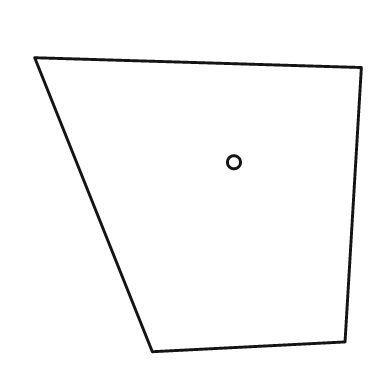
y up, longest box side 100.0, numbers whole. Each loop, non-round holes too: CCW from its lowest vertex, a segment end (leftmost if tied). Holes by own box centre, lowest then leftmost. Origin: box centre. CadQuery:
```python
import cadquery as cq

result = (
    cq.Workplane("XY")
    .moveTo(-14.0, -45.0)
    .lineTo(45.0, -42.0)
    .lineTo(50.0, 42.0)
    .lineTo(-50.0, 45.0)
    .close()
    .moveTo(11.0, 13.0)
    .circle(2.0)
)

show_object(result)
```